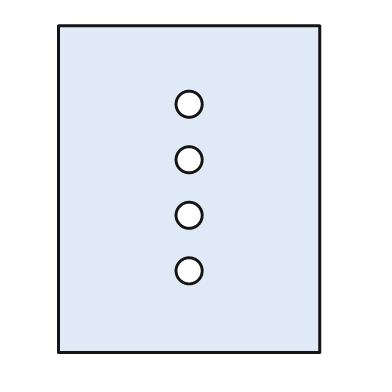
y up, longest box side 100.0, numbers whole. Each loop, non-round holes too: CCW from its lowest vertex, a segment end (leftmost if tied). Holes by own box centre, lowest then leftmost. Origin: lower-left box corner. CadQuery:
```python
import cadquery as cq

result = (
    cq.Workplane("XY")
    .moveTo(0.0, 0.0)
    .lineTo(80.0, 0.0)
    .lineTo(80.0, 100.0)
    .lineTo(0.0, 100.0)
    .close()
    .moveTo(40.0, 25.0)
    .circle(4.0)
    .moveTo(40.0, 42.0)
    .circle(4.0)
    .moveTo(40.0, 59.0)
    .circle(4.0)
    .moveTo(40.0, 76.0)
    .circle(4.0)
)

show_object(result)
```